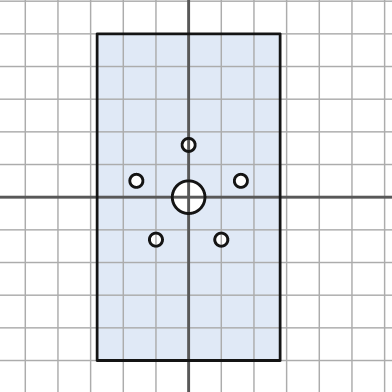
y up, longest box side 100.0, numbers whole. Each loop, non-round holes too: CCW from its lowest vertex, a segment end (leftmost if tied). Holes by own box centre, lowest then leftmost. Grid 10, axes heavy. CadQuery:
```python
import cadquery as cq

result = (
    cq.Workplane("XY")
    .moveTo(-28.0, -50.0)
    .lineTo(28.0, -50.0)
    .lineTo(28.0, 50.0)
    .lineTo(-28.0, 50.0)
    .close()
    .moveTo(-10.0, -13.0)
    .circle(2.0)
    .moveTo(10.0, -13.0)
    .circle(2.0)
    .moveTo(0.0, 0.0)
    .circle(5.0)
    .moveTo(-16.0, 5.0)
    .circle(2.0)
    .moveTo(16.0, 5.0)
    .circle(2.0)
    .moveTo(0.0, 16.0)
    .circle(2.0)
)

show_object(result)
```